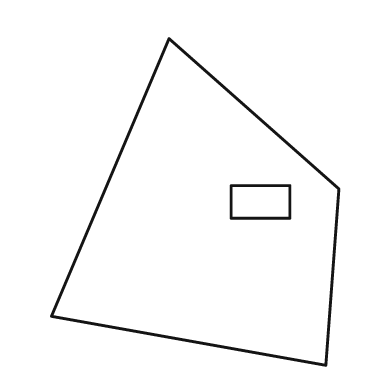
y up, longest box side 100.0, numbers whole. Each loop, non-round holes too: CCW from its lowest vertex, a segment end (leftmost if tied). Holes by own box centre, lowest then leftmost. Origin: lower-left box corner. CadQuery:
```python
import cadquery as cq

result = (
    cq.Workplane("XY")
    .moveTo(84.0, 0.0)
    .lineTo(88.0, 54.0)
    .lineTo(36.0, 100.0)
    .lineTo(0.0, 15.0)
    .close()
    .moveTo(55.0, 45.0)
    .lineTo(73.0, 45.0)
    .lineTo(73.0, 55.0)
    .lineTo(55.0, 55.0)
    .close()
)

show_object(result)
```